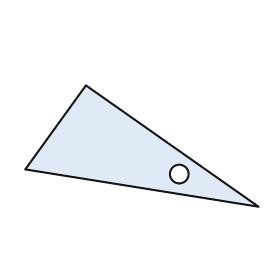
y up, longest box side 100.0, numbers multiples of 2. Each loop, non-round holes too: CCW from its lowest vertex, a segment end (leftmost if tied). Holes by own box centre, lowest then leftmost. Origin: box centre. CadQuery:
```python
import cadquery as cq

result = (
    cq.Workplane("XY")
    .moveTo(50.0, -26.0)
    .lineTo(-24.0, 26.0)
    .lineTo(-50.0, -10.0)
    .close()
    .moveTo(16.0, -12.0)
    .circle(4.0)
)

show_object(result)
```